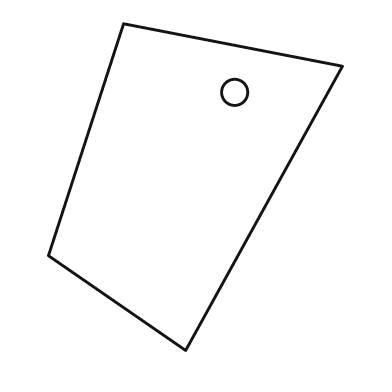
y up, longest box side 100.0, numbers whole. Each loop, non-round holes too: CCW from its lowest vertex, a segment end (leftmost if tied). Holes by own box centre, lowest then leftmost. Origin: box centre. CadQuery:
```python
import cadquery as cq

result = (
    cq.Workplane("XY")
    .moveTo(-3.0, -50.0)
    .lineTo(45.0, 37.0)
    .lineTo(-22.0, 50.0)
    .lineTo(-45.0, -21.0)
    .close()
    .moveTo(12.0, 29.0)
    .circle(4.0)
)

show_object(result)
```